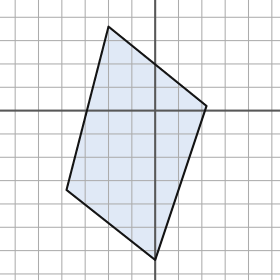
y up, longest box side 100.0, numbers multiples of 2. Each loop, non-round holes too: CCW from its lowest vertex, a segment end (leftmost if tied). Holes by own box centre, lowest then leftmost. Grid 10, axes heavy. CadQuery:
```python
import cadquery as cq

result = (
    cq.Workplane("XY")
    .moveTo(0.0, -64.0)
    .lineTo(22.0, 2.0)
    .lineTo(-20.0, 36.0)
    .lineTo(-38.0, -34.0)
    .close()
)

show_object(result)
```